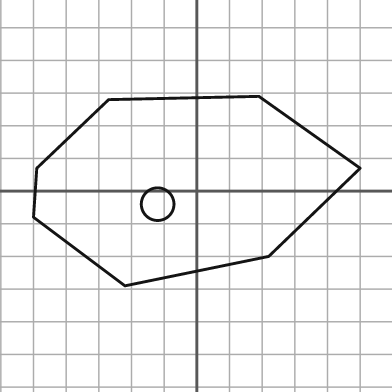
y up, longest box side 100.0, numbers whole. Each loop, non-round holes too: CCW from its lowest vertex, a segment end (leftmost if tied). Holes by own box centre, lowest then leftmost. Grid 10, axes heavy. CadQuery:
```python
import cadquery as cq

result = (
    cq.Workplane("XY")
    .moveTo(-22.0, -29.0)
    .lineTo(22.0, -20.0)
    .lineTo(50.0, 7.0)
    .lineTo(19.0, 29.0)
    .lineTo(-27.0, 28.0)
    .lineTo(-49.0, 7.0)
    .lineTo(-50.0, -8.0)
    .close()
    .moveTo(-12.0, -4.0)
    .circle(5.0)
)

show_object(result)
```